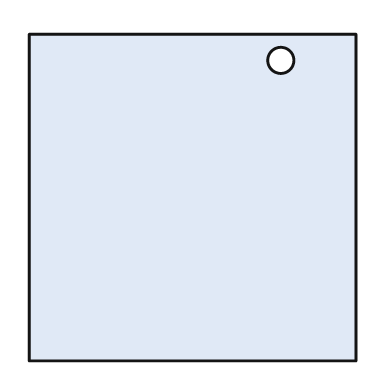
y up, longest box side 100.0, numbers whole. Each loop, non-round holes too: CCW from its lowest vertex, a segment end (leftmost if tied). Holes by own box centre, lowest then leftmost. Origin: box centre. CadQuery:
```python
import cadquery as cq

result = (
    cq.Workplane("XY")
    .moveTo(-50.0, -50.0)
    .lineTo(50.0, -50.0)
    .lineTo(50.0, 50.0)
    .lineTo(-50.0, 50.0)
    .close()
    .moveTo(27.0, 42.0)
    .circle(4.0)
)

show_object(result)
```